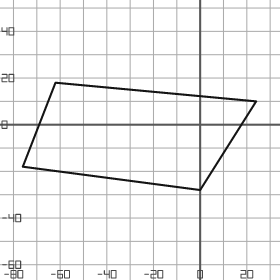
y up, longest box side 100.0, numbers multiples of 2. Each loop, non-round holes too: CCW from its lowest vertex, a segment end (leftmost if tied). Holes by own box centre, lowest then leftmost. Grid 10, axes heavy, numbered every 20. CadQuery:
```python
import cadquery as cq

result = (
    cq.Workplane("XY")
    .moveTo(0.0, -28.0)
    .lineTo(24.0, 10.0)
    .lineTo(-62.0, 18.0)
    .lineTo(-76.0, -18.0)
    .close()
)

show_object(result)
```